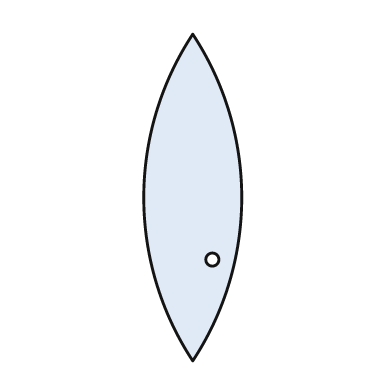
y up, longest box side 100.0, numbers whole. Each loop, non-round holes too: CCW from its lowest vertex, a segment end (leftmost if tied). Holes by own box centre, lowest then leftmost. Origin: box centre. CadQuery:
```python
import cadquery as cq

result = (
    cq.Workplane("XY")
    .moveTo(0.0, -50.0)
    .threePointArc((15.0, 0.0), (0.0, 50.0))
    .threePointArc((-15.0, 0.0), (0.0, -50.0))
    .close()
    .moveTo(6.0, -19.0)
    .circle(2.0)
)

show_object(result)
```